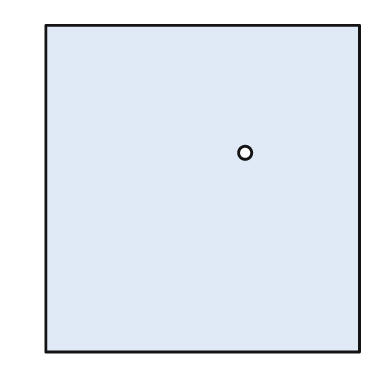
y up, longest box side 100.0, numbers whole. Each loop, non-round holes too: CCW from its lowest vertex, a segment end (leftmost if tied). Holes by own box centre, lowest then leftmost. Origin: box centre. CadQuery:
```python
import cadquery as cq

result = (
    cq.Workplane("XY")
    .moveTo(-48.0, -50.0)
    .lineTo(48.0, -50.0)
    .lineTo(48.0, 50.0)
    .lineTo(-48.0, 50.0)
    .close()
    .moveTo(13.0, 11.0)
    .circle(2.0)
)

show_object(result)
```